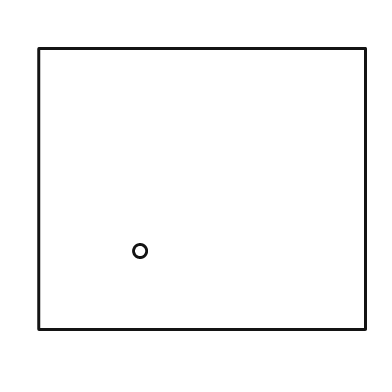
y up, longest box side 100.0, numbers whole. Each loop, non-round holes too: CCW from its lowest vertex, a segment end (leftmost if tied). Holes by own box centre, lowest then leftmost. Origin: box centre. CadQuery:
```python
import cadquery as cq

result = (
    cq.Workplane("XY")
    .moveTo(-50.0, -43.0)
    .lineTo(50.0, -43.0)
    .lineTo(50.0, 43.0)
    .lineTo(-50.0, 43.0)
    .close()
    .moveTo(-19.0, -19.0)
    .circle(2.0)
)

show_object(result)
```